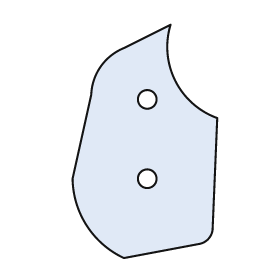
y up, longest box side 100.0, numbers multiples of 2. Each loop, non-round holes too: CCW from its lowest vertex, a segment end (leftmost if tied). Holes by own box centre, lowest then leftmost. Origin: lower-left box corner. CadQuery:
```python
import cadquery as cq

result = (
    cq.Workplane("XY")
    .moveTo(22.0, 0.0)
    .lineTo(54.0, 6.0)
    .threePointArc((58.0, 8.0), (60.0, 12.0))
    .lineTo(62.0, 60.0)
    .threePointArc((44.0, 76.0), (42.0, 100.0))
    .lineTo(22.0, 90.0)
    .threePointArc((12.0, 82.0), (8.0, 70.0))
    .lineTo(0.0, 34.0)
    .threePointArc((6.0, 14.0), (22.0, 0.0))
    .close()
    .moveTo(32.0, 34.0)
    .circle(4.0)
    .moveTo(32.0, 68.0)
    .circle(4.0)
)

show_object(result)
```